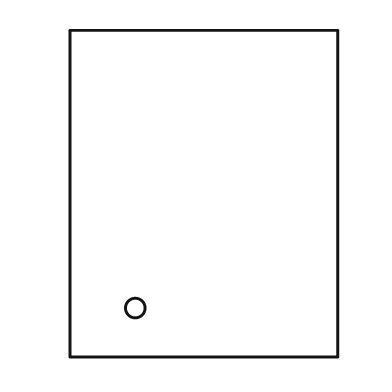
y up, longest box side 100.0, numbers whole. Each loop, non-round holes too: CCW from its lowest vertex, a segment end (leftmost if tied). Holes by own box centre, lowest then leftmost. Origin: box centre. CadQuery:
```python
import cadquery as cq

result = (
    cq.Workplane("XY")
    .moveTo(-41.0, -50.0)
    .lineTo(41.0, -50.0)
    .lineTo(41.0, 50.0)
    .lineTo(-41.0, 50.0)
    .close()
    .moveTo(-21.0, -35.0)
    .circle(3.0)
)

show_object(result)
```